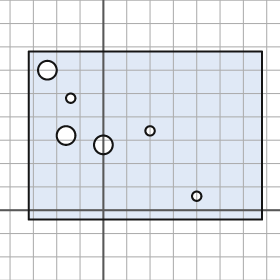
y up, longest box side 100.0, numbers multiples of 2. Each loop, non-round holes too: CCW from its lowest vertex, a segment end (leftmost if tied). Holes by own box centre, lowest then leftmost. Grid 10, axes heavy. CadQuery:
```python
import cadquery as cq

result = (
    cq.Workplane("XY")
    .moveTo(-32.0, -4.0)
    .lineTo(68.0, -4.0)
    .lineTo(68.0, 68.0)
    .lineTo(-32.0, 68.0)
    .close()
    .moveTo(40.0, 6.0)
    .circle(2.0)
    .moveTo(0.0, 28.0)
    .circle(4.0)
    .moveTo(-16.0, 32.0)
    .circle(4.0)
    .moveTo(20.0, 34.0)
    .circle(2.0)
    .moveTo(-14.0, 48.0)
    .circle(2.0)
    .moveTo(-24.0, 60.0)
    .circle(4.0)
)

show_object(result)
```